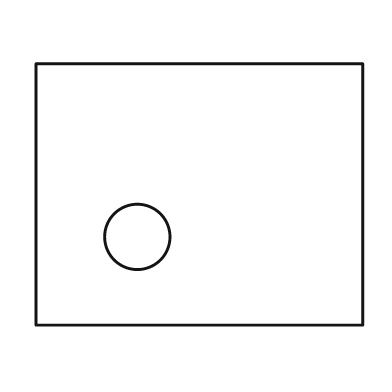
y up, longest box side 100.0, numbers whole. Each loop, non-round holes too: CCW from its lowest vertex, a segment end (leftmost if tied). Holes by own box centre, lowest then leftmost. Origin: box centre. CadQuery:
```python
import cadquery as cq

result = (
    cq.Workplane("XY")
    .moveTo(-50.0, -40.0)
    .lineTo(50.0, -40.0)
    .lineTo(50.0, 40.0)
    .lineTo(-50.0, 40.0)
    .close()
    .moveTo(-19.0, -13.0)
    .circle(10.0)
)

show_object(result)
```